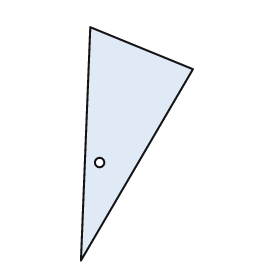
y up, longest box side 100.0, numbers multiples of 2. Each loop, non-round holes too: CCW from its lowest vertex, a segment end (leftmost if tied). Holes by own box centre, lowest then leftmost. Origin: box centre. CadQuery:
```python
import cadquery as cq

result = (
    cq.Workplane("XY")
    .moveTo(-24.0, -50.0)
    .lineTo(24.0, 32.0)
    .lineTo(-20.0, 50.0)
    .close()
    .moveTo(-16.0, -8.0)
    .circle(2.0)
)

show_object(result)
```